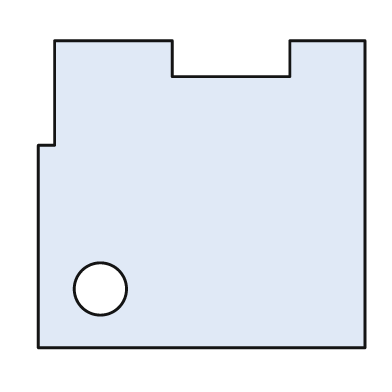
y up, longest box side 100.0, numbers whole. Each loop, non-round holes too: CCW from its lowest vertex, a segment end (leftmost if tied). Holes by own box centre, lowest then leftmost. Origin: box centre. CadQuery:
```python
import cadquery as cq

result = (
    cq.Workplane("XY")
    .moveTo(-50.0, -47.0)
    .lineTo(50.0, -47.0)
    .lineTo(50.0, 47.0)
    .lineTo(27.0, 47.0)
    .lineTo(27.0, 36.0)
    .lineTo(-9.0, 36.0)
    .lineTo(-9.0, 47.0)
    .lineTo(-45.0, 47.0)
    .lineTo(-45.0, 15.0)
    .lineTo(-50.0, 15.0)
    .close()
    .moveTo(-31.0, -29.0)
    .circle(8.0)
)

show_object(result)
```